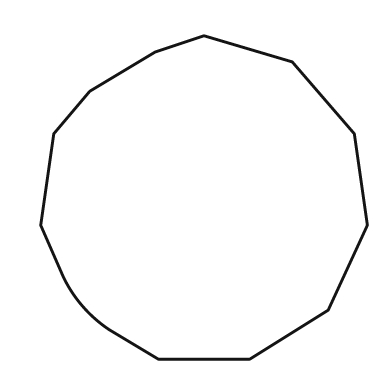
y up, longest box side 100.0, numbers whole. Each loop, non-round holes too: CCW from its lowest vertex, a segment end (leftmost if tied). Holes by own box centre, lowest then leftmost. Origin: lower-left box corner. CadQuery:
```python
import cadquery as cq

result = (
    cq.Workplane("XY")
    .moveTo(36.0, 0.0)
    .lineTo(64.0, 0.0)
    .lineTo(88.0, 15.0)
    .lineTo(100.0, 41.0)
    .lineTo(96.0, 69.0)
    .lineTo(77.0, 91.0)
    .lineTo(50.0, 99.0)
    .lineTo(35.0, 94.0)
    .lineTo(15.0, 82.0)
    .lineTo(4.0, 69.0)
    .lineTo(0.0, 41.0)
    .lineTo(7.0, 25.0)
    .threePointArc((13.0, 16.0), (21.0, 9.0))
    .close()
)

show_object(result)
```